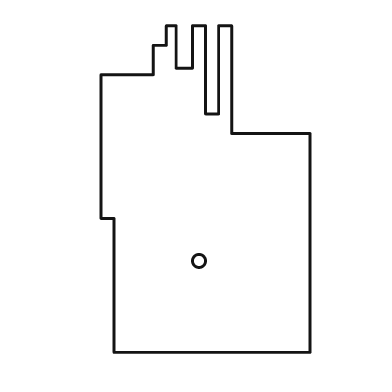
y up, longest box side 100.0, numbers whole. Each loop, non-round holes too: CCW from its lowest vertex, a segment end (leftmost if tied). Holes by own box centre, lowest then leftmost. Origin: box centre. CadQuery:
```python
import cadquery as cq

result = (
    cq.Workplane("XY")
    .moveTo(-28.0, -50.0)
    .lineTo(32.0, -50.0)
    .lineTo(32.0, 17.0)
    .lineTo(8.0, 17.0)
    .lineTo(8.0, 50.0)
    .lineTo(4.0, 50.0)
    .lineTo(4.0, 23.0)
    .lineTo(0.0, 23.0)
    .lineTo(0.0, 50.0)
    .lineTo(-4.0, 50.0)
    .lineTo(-4.0, 37.0)
    .lineTo(-9.0, 37.0)
    .lineTo(-9.0, 50.0)
    .lineTo(-12.0, 50.0)
    .lineTo(-12.0, 44.0)
    .lineTo(-16.0, 44.0)
    .lineTo(-16.0, 35.0)
    .lineTo(-32.0, 35.0)
    .lineTo(-32.0, -9.0)
    .lineTo(-28.0, -9.0)
    .close()
    .moveTo(-2.0, -22.0)
    .circle(2.0)
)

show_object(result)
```